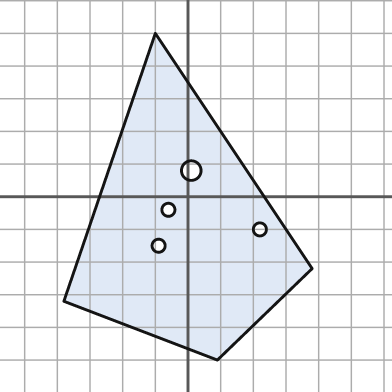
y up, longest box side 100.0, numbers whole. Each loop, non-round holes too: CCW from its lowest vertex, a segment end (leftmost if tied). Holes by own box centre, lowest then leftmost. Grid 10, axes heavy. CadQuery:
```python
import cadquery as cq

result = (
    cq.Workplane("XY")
    .moveTo(9.0, -50.0)
    .lineTo(38.0, -22.0)
    .lineTo(-10.0, 50.0)
    .lineTo(-38.0, -32.0)
    .close()
    .moveTo(-9.0, -15.0)
    .circle(2.0)
    .moveTo(22.0, -10.0)
    .circle(2.0)
    .moveTo(-6.0, -4.0)
    .circle(2.0)
    .moveTo(1.0, 8.0)
    .circle(3.0)
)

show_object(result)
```